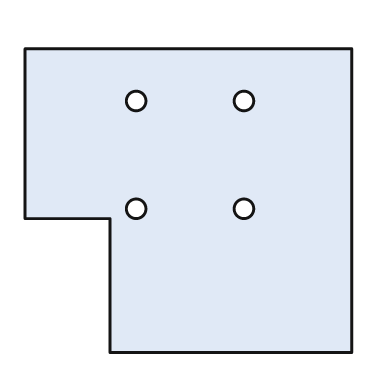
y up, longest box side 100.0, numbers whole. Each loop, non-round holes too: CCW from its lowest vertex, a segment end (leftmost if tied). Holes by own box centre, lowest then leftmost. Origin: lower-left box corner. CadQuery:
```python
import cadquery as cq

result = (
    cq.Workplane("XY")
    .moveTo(26.0, 0.0)
    .lineTo(100.0, 0.0)
    .lineTo(100.0, 93.0)
    .lineTo(0.0, 93.0)
    .lineTo(0.0, 41.0)
    .lineTo(26.0, 41.0)
    .close()
    .moveTo(34.0, 44.0)
    .circle(3.0)
    .moveTo(67.0, 44.0)
    .circle(3.0)
    .moveTo(34.0, 77.0)
    .circle(3.0)
    .moveTo(67.0, 77.0)
    .circle(3.0)
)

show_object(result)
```